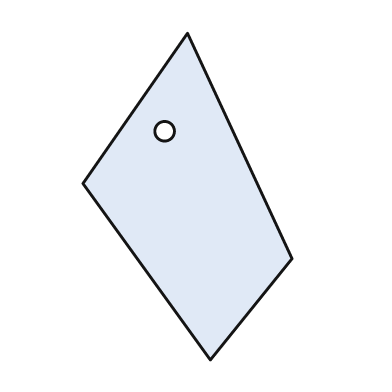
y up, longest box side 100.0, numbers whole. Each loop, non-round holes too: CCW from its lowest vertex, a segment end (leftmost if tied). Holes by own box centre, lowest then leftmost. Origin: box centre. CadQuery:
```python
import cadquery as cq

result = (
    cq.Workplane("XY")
    .moveTo(7.0, -50.0)
    .lineTo(32.0, -19.0)
    .lineTo(0.0, 50.0)
    .lineTo(-32.0, 4.0)
    .close()
    .moveTo(-7.0, 20.0)
    .circle(3.0)
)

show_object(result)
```